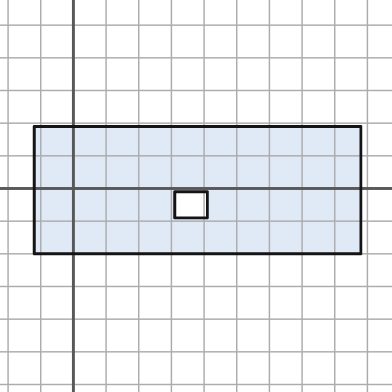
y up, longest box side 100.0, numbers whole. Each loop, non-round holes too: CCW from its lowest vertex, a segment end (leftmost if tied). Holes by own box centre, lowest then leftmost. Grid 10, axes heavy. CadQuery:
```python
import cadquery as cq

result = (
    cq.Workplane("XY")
    .moveTo(-12.0, -20.0)
    .lineTo(88.0, -20.0)
    .lineTo(88.0, 19.0)
    .lineTo(-12.0, 19.0)
    .close()
    .moveTo(31.0, -9.0)
    .lineTo(41.0, -9.0)
    .lineTo(41.0, -1.0)
    .lineTo(31.0, -1.0)
    .close()
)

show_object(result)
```